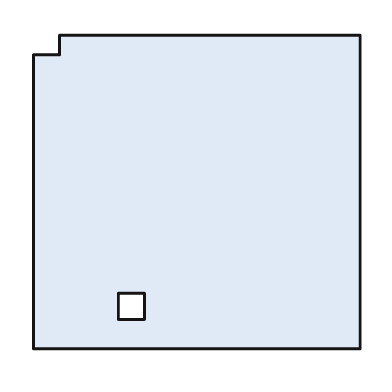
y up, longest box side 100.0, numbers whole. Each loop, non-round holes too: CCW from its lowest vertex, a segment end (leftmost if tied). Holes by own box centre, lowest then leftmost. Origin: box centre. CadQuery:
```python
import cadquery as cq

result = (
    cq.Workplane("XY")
    .moveTo(-50.0, -48.0)
    .lineTo(50.0, -48.0)
    .lineTo(50.0, 48.0)
    .lineTo(-42.0, 48.0)
    .lineTo(-42.0, 42.0)
    .lineTo(-50.0, 42.0)
    .close()
    .moveTo(-24.0, -39.0)
    .lineTo(-16.0, -39.0)
    .lineTo(-16.0, -31.0)
    .lineTo(-24.0, -31.0)
    .close()
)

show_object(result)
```